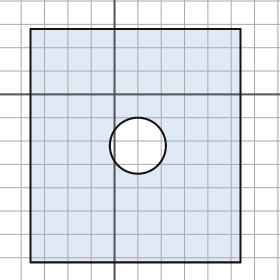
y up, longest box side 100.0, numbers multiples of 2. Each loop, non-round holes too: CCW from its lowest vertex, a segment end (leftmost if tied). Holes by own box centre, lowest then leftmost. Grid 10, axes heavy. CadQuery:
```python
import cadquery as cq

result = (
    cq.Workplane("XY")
    .moveTo(-36.0, -72.0)
    .lineTo(54.0, -72.0)
    .lineTo(54.0, 28.0)
    .lineTo(-36.0, 28.0)
    .close()
    .moveTo(10.0, -22.0)
    .circle(12.0)
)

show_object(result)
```